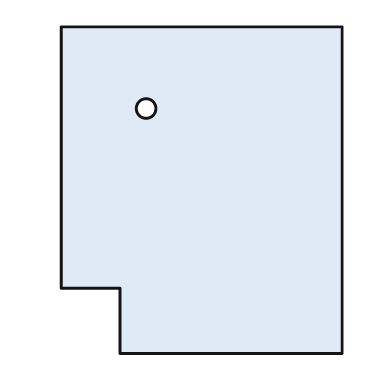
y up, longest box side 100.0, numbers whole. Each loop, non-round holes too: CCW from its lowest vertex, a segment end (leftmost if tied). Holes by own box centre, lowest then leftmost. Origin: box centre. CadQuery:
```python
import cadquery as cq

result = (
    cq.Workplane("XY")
    .moveTo(-25.0, -50.0)
    .lineTo(43.0, -50.0)
    .lineTo(43.0, 50.0)
    .lineTo(-43.0, 50.0)
    .lineTo(-43.0, -30.0)
    .lineTo(-25.0, -30.0)
    .close()
    .moveTo(-17.0, 25.0)
    .circle(3.0)
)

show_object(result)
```